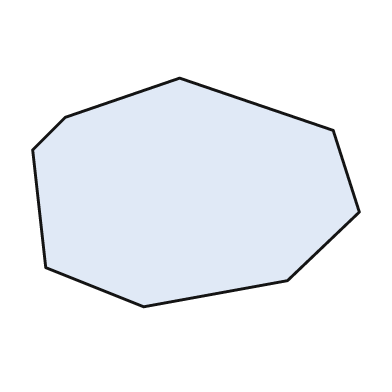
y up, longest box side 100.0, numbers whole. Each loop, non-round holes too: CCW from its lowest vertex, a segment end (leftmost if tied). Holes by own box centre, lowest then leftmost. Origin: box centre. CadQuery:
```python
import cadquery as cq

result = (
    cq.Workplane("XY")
    .moveTo(-16.0, -35.0)
    .lineTo(28.0, -27.0)
    .lineTo(50.0, -6.0)
    .lineTo(42.0, 19.0)
    .lineTo(-5.0, 35.0)
    .lineTo(-40.0, 23.0)
    .lineTo(-50.0, 13.0)
    .lineTo(-46.0, -23.0)
    .close()
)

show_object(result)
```